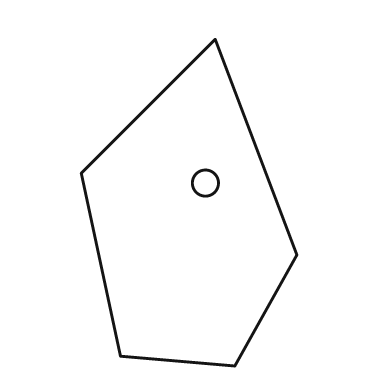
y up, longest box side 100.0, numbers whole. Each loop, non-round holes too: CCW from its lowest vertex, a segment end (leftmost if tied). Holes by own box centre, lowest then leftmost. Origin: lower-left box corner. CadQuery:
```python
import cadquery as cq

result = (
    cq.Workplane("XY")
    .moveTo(47.0, 0.0)
    .lineTo(66.0, 34.0)
    .lineTo(41.0, 100.0)
    .lineTo(0.0, 59.0)
    .lineTo(12.0, 3.0)
    .close()
    .moveTo(38.0, 56.0)
    .circle(4.0)
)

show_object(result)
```